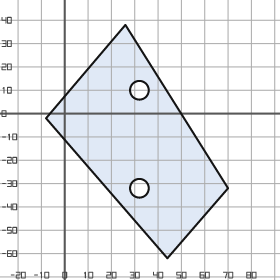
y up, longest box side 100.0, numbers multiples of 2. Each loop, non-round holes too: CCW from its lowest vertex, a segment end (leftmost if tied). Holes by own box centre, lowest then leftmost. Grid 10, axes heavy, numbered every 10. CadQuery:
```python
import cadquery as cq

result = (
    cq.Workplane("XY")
    .moveTo(44.0, -62.0)
    .lineTo(70.0, -32.0)
    .lineTo(26.0, 38.0)
    .lineTo(-8.0, -2.0)
    .close()
    .moveTo(32.0, -32.0)
    .circle(4.0)
    .moveTo(32.0, 10.0)
    .circle(4.0)
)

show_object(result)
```